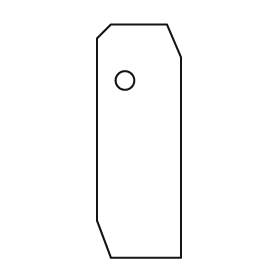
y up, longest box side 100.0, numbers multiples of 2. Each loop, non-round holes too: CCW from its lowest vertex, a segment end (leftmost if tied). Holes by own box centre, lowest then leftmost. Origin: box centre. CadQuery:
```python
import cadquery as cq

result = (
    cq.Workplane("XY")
    .moveTo(-12.0, -50.0)
    .lineTo(18.0, -50.0)
    .lineTo(18.0, 36.0)
    .lineTo(12.0, 50.0)
    .lineTo(-12.0, 50.0)
    .lineTo(-18.0, 44.0)
    .lineTo(-18.0, -34.0)
    .close()
    .moveTo(-6.0, 26.0)
    .circle(4.0)
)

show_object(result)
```